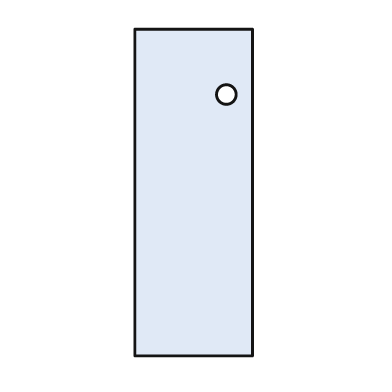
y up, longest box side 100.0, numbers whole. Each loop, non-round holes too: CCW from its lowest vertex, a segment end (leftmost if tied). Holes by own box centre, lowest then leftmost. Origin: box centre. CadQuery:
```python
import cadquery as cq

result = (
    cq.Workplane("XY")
    .moveTo(-18.0, -50.0)
    .lineTo(18.0, -50.0)
    .lineTo(18.0, 50.0)
    .lineTo(-18.0, 50.0)
    .close()
    .moveTo(10.0, 30.0)
    .circle(3.0)
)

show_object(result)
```